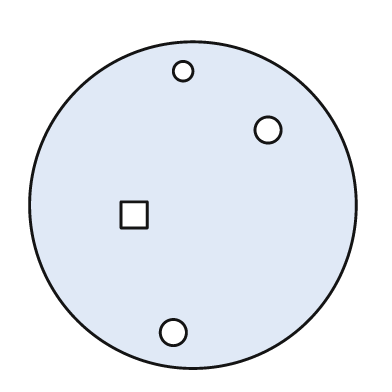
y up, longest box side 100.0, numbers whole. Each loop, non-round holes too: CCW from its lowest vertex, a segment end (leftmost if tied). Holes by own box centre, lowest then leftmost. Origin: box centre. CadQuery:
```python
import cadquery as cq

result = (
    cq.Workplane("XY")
    .moveTo(0.0, 0.0)
    .circle(50.0)
    .moveTo(-6.0, -39.0)
    .circle(4.0)
    .moveTo(-22.0, -7.0)
    .lineTo(-14.0, -7.0)
    .lineTo(-14.0, 1.0)
    .lineTo(-22.0, 1.0)
    .close()
    .moveTo(23.0, 23.0)
    .circle(4.0)
    .moveTo(-3.0, 41.0)
    .circle(3.0)
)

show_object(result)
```